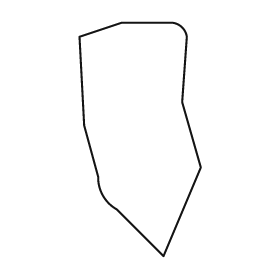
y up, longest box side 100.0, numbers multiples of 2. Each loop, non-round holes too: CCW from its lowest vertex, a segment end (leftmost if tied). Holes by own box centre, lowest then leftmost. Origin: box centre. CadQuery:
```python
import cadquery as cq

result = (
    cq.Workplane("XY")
    .moveTo(10.0, -50.0)
    .lineTo(26.0, -12.0)
    .lineTo(18.0, 16.0)
    .lineTo(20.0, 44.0)
    .threePointArc((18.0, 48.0), (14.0, 50.0))
    .lineTo(-8.0, 50.0)
    .lineTo(-26.0, 44.0)
    .lineTo(-24.0, 6.0)
    .lineTo(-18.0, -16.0)
    .threePointArc((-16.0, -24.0), (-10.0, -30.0))
    .close()
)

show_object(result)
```